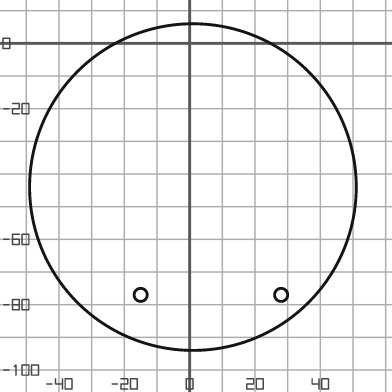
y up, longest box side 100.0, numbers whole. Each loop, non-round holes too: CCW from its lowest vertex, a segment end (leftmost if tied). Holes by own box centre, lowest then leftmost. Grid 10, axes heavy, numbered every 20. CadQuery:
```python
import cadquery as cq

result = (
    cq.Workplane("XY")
    .moveTo(1.0, -44.0)
    .circle(50.0)
    .moveTo(-15.0, -77.0)
    .circle(2.0)
    .moveTo(28.0, -77.0)
    .circle(2.0)
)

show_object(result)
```